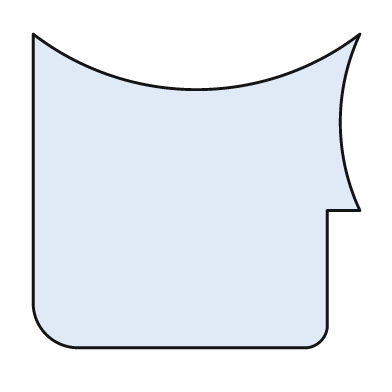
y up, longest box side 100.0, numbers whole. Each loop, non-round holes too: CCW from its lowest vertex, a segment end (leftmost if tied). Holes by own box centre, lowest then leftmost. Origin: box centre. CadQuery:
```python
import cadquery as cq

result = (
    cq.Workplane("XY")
    .moveTo(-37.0, -48.0)
    .lineTo(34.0, -48.0)
    .threePointArc((38.0, -46.0), (40.0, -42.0))
    .lineTo(40.0, -6.0)
    .lineTo(50.0, -6.0)
    .threePointArc((44.0, 21.0), (50.0, 48.0))
    .threePointArc((0.0, 31.0), (-50.0, 48.0))
    .lineTo(-50.0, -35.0)
    .threePointArc((-46.0, -44.0), (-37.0, -48.0))
    .close()
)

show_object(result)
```